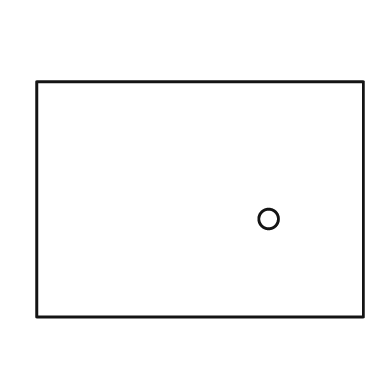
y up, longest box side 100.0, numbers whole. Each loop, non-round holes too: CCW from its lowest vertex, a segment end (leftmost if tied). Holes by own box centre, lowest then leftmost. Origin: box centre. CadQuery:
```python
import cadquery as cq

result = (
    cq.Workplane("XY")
    .moveTo(-50.0, -36.0)
    .lineTo(50.0, -36.0)
    .lineTo(50.0, 36.0)
    .lineTo(-50.0, 36.0)
    .close()
    .moveTo(21.0, -6.0)
    .circle(3.0)
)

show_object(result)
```